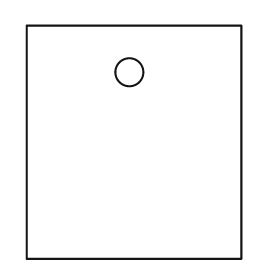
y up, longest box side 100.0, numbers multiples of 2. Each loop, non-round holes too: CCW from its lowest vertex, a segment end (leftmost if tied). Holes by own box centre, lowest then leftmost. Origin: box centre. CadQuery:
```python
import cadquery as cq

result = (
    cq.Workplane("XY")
    .moveTo(-46.0, -50.0)
    .lineTo(46.0, -50.0)
    .lineTo(46.0, 50.0)
    .lineTo(-46.0, 50.0)
    .close()
    .moveTo(-2.0, 30.0)
    .circle(6.0)
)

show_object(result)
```